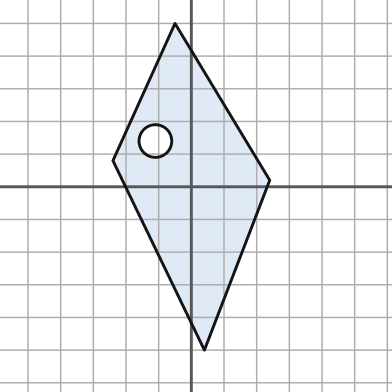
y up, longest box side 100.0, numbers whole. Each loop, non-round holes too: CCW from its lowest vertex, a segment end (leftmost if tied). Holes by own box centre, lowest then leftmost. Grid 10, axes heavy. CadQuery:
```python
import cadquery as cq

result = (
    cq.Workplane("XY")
    .moveTo(4.0, -50.0)
    .lineTo(24.0, 2.0)
    .lineTo(-5.0, 50.0)
    .lineTo(-24.0, 8.0)
    .close()
    .moveTo(-11.0, 14.0)
    .circle(5.0)
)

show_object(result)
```